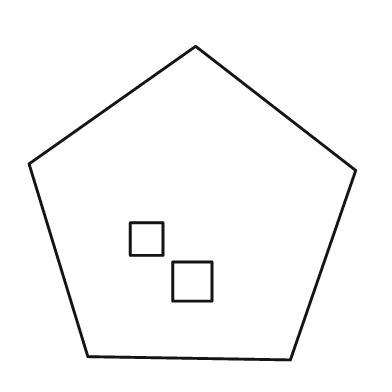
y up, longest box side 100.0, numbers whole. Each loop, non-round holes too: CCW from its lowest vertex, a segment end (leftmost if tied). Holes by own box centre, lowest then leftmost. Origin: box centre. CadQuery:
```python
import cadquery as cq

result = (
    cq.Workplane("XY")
    .moveTo(30.0, -48.0)
    .lineTo(50.0, 10.0)
    .lineTo(1.0, 48.0)
    .lineTo(-50.0, 12.0)
    .lineTo(-32.0, -47.0)
    .close()
    .moveTo(-6.0, -30.0)
    .lineTo(6.0, -30.0)
    .lineTo(6.0, -18.0)
    .lineTo(-6.0, -18.0)
    .close()
    .moveTo(-19.0, -16.0)
    .lineTo(-9.0, -16.0)
    .lineTo(-9.0, -6.0)
    .lineTo(-19.0, -6.0)
    .close()
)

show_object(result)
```